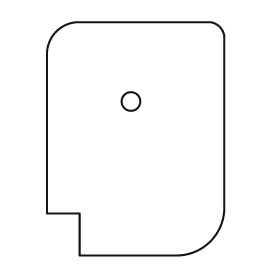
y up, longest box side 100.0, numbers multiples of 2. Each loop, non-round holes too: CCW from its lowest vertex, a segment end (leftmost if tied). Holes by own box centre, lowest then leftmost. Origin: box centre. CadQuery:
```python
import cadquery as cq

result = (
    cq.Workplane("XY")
    .moveTo(-24.0, -50.0)
    .lineTo(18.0, -50.0)
    .threePointArc((32.0, -44.0), (38.0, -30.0))
    .lineTo(38.0, 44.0)
    .threePointArc((36.0, 48.0), (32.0, 50.0))
    .lineTo(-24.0, 50.0)
    .threePointArc((-34.0, 46.0), (-38.0, 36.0))
    .lineTo(-38.0, -32.0)
    .lineTo(-24.0, -32.0)
    .close()
    .moveTo(-2.0, 16.0)
    .circle(4.0)
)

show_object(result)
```